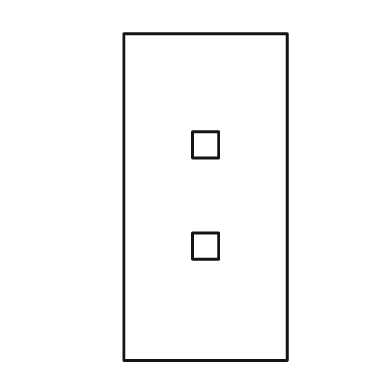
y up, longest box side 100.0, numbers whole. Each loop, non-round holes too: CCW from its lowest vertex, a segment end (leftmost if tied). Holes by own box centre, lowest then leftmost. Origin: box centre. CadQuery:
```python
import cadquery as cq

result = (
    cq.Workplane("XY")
    .moveTo(-25.0, -50.0)
    .lineTo(25.0, -50.0)
    .lineTo(25.0, 50.0)
    .lineTo(-25.0, 50.0)
    .close()
    .moveTo(-4.0, -19.0)
    .lineTo(4.0, -19.0)
    .lineTo(4.0, -11.0)
    .lineTo(-4.0, -11.0)
    .close()
    .moveTo(-4.0, 12.0)
    .lineTo(4.0, 12.0)
    .lineTo(4.0, 20.0)
    .lineTo(-4.0, 20.0)
    .close()
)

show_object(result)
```